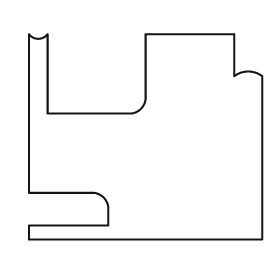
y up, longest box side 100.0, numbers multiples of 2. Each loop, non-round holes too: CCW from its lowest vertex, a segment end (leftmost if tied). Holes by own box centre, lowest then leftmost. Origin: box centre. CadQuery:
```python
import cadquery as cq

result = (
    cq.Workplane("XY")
    .moveTo(-50.0, -44.0)
    .lineTo(50.0, -44.0)
    .lineTo(50.0, 26.0)
    .threePointArc((44.0, 28.0), (38.0, 26.0))
    .lineTo(38.0, 44.0)
    .lineTo(0.0, 44.0)
    .lineTo(0.0, 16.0)
    .threePointArc((-2.0, 12.0), (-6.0, 10.0))
    .lineTo(-42.0, 10.0)
    .lineTo(-42.0, 44.0)
    .threePointArc((-46.0, 42.0), (-50.0, 44.0))
    .lineTo(-50.0, -24.0)
    .lineTo(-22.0, -24.0)
    .threePointArc((-18.0, -26.0), (-16.0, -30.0))
    .lineTo(-16.0, -38.0)
    .lineTo(-50.0, -38.0)
    .close()
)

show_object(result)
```